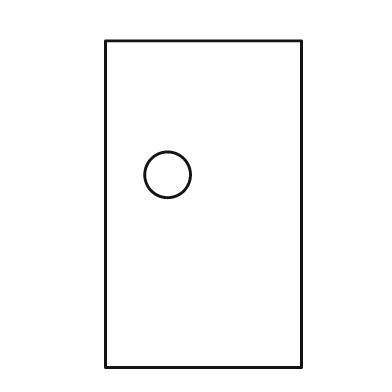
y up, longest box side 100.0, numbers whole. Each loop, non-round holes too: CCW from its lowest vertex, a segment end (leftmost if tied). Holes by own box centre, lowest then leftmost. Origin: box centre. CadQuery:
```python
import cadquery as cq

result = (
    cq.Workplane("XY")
    .moveTo(-30.0, -50.0)
    .lineTo(30.0, -50.0)
    .lineTo(30.0, 50.0)
    .lineTo(-30.0, 50.0)
    .close()
    .moveTo(-11.0, 9.0)
    .circle(7.0)
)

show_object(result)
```